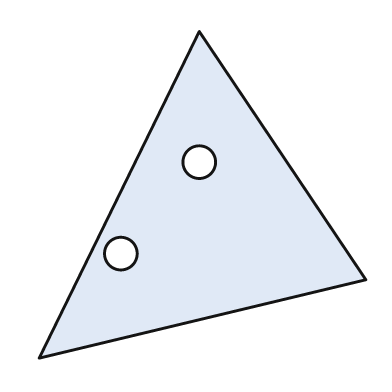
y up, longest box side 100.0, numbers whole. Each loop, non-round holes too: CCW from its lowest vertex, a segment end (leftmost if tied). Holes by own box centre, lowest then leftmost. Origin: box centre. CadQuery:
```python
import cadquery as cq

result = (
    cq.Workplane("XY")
    .moveTo(-50.0, -50.0)
    .lineTo(50.0, -26.0)
    .lineTo(-1.0, 50.0)
    .close()
    .moveTo(-25.0, -18.0)
    .circle(5.0)
    .moveTo(-1.0, 10.0)
    .circle(5.0)
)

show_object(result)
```